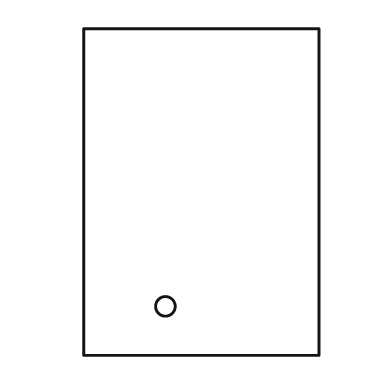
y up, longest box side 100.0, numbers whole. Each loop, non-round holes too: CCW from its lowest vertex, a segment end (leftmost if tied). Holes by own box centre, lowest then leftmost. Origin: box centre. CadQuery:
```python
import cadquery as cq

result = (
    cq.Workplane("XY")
    .moveTo(-36.0, -50.0)
    .lineTo(36.0, -50.0)
    .lineTo(36.0, 50.0)
    .lineTo(-36.0, 50.0)
    .close()
    .moveTo(-11.0, -35.0)
    .circle(3.0)
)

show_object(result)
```